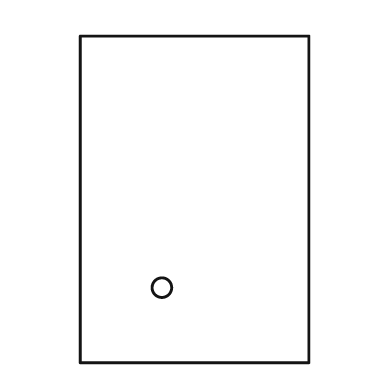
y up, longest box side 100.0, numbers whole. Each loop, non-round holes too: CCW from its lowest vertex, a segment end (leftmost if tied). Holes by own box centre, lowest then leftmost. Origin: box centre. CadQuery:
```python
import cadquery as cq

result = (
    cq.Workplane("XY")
    .moveTo(-35.0, -50.0)
    .lineTo(35.0, -50.0)
    .lineTo(35.0, 50.0)
    .lineTo(-35.0, 50.0)
    .close()
    .moveTo(-10.0, -27.0)
    .circle(3.0)
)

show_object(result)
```